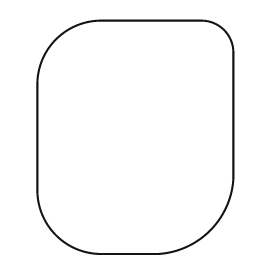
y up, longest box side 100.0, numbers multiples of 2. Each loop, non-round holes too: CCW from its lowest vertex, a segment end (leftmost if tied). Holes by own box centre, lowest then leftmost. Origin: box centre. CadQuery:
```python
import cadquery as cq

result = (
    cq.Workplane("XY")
    .moveTo(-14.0, -50.0)
    .lineTo(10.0, -50.0)
    .threePointArc((32.0, -40.0), (42.0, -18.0))
    .lineTo(42.0, 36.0)
    .threePointArc((38.0, 46.0), (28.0, 50.0))
    .lineTo(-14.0, 50.0)
    .threePointArc((-34.0, 42.0), (-42.0, 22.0))
    .lineTo(-42.0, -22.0)
    .threePointArc((-34.0, -42.0), (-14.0, -50.0))
    .close()
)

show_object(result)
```